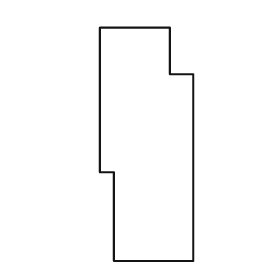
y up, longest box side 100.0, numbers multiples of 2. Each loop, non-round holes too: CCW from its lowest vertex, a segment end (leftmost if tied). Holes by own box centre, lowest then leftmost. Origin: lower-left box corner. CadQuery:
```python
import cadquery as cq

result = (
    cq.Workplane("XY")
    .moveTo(6.0, 0.0)
    .lineTo(40.0, 0.0)
    .lineTo(40.0, 80.0)
    .lineTo(30.0, 80.0)
    .lineTo(30.0, 100.0)
    .lineTo(0.0, 100.0)
    .lineTo(0.0, 38.0)
    .lineTo(6.0, 38.0)
    .close()
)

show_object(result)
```